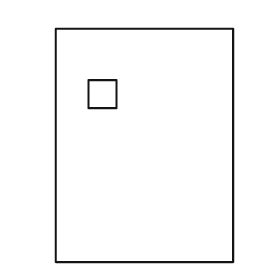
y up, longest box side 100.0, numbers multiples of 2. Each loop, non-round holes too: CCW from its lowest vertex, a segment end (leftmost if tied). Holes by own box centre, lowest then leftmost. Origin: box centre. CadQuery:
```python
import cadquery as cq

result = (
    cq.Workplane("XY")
    .moveTo(-38.0, -50.0)
    .lineTo(38.0, -50.0)
    .lineTo(38.0, 50.0)
    .lineTo(-38.0, 50.0)
    .close()
    .moveTo(-24.0, 16.0)
    .lineTo(-12.0, 16.0)
    .lineTo(-12.0, 28.0)
    .lineTo(-24.0, 28.0)
    .close()
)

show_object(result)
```